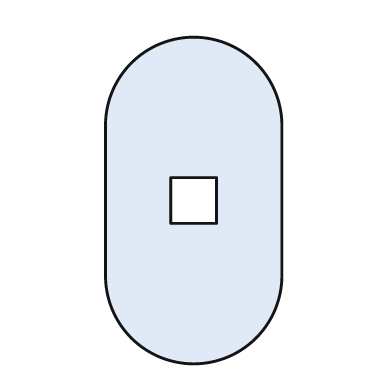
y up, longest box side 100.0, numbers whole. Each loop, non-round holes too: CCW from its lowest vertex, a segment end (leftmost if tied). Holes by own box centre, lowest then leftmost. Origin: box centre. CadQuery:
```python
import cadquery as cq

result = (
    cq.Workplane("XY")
    .moveTo(-27.0, -23.0)
    .threePointArc((0.0, -50.0), (27.0, -23.0))
    .lineTo(27.0, 23.0)
    .threePointArc((0.0, 50.0), (-27.0, 23.0))
    .close()
    .moveTo(-7.0, -7.0)
    .lineTo(7.0, -7.0)
    .lineTo(7.0, 7.0)
    .lineTo(-7.0, 7.0)
    .close()
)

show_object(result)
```